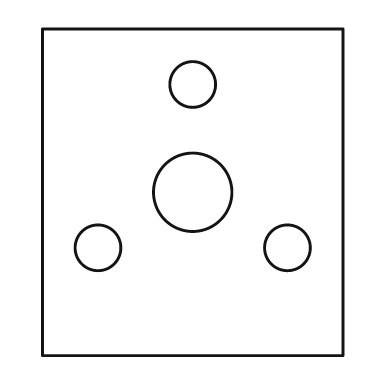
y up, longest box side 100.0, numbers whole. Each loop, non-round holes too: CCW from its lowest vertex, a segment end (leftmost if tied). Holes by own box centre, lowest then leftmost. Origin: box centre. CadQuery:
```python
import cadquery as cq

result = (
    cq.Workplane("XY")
    .moveTo(-46.0, -50.0)
    .lineTo(46.0, -50.0)
    .lineTo(46.0, 50.0)
    .lineTo(-46.0, 50.0)
    .close()
    .moveTo(-29.0, -17.0)
    .circle(7.0)
    .moveTo(29.0, -17.0)
    .circle(7.0)
    .moveTo(0.0, 0.0)
    .circle(12.0)
    .moveTo(0.0, 33.0)
    .circle(7.0)
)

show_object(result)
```